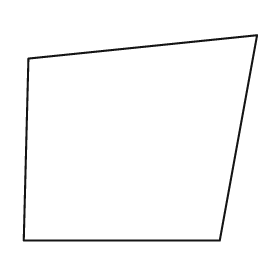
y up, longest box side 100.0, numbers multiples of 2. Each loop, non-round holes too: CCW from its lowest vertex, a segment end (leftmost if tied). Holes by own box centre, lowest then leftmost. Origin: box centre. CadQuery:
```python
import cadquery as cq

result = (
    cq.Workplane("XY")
    .moveTo(-50.0, -44.0)
    .lineTo(34.0, -44.0)
    .lineTo(50.0, 44.0)
    .lineTo(-48.0, 34.0)
    .close()
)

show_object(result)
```